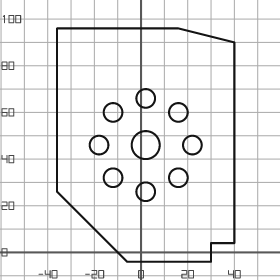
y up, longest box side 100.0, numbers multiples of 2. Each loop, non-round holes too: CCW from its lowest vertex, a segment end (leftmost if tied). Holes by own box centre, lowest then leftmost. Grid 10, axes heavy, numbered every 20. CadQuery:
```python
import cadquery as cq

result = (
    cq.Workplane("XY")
    .moveTo(-6.0, -4.0)
    .lineTo(30.0, -4.0)
    .lineTo(30.0, 4.0)
    .lineTo(40.0, 4.0)
    .lineTo(40.0, 90.0)
    .lineTo(16.0, 96.0)
    .lineTo(-36.0, 96.0)
    .lineTo(-36.0, 26.0)
    .close()
    .moveTo(2.0, 26.0)
    .circle(4.0)
    .moveTo(-12.0, 32.0)
    .circle(4.0)
    .moveTo(16.0, 32.0)
    .circle(4.0)
    .moveTo(-18.0, 46.0)
    .circle(4.0)
    .moveTo(2.0, 46.0)
    .circle(6.0)
    .moveTo(22.0, 46.0)
    .circle(4.0)
    .moveTo(-12.0, 60.0)
    .circle(4.0)
    .moveTo(16.0, 60.0)
    .circle(4.0)
    .moveTo(2.0, 66.0)
    .circle(4.0)
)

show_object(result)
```